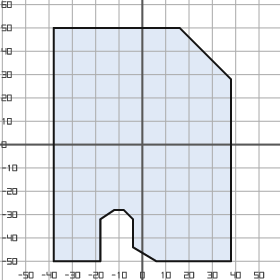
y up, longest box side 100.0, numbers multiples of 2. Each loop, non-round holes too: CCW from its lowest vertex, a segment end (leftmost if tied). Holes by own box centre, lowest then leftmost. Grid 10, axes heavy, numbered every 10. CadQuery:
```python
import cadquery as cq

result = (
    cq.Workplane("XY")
    .moveTo(-38.0, -50.0)
    .lineTo(-18.0, -50.0)
    .lineTo(-18.0, -32.0)
    .lineTo(-12.0, -28.0)
    .lineTo(-8.0, -28.0)
    .lineTo(-4.0, -32.0)
    .lineTo(-4.0, -44.0)
    .lineTo(6.0, -50.0)
    .lineTo(38.0, -50.0)
    .lineTo(38.0, 28.0)
    .lineTo(16.0, 50.0)
    .lineTo(-38.0, 50.0)
    .close()
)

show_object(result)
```